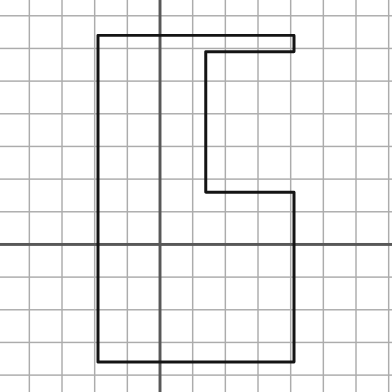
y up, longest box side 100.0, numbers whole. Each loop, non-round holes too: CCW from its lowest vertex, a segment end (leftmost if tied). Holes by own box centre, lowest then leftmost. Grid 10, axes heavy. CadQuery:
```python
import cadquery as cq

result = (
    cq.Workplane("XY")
    .moveTo(-19.0, -36.0)
    .lineTo(41.0, -36.0)
    .lineTo(41.0, 16.0)
    .lineTo(14.0, 16.0)
    .lineTo(14.0, 59.0)
    .lineTo(41.0, 59.0)
    .lineTo(41.0, 64.0)
    .lineTo(-19.0, 64.0)
    .close()
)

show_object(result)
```